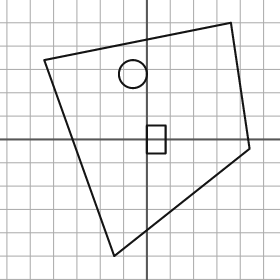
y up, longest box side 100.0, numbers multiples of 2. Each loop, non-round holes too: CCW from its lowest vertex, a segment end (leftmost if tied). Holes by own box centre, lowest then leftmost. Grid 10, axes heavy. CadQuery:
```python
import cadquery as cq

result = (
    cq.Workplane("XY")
    .moveTo(-14.0, -50.0)
    .lineTo(44.0, -4.0)
    .lineTo(36.0, 50.0)
    .lineTo(-44.0, 34.0)
    .close()
    .moveTo(0.0, -6.0)
    .lineTo(8.0, -6.0)
    .lineTo(8.0, 6.0)
    .lineTo(0.0, 6.0)
    .close()
    .moveTo(-6.0, 28.0)
    .circle(6.0)
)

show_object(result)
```